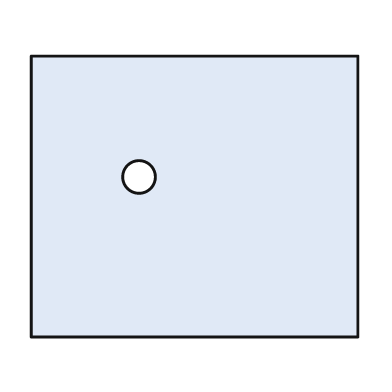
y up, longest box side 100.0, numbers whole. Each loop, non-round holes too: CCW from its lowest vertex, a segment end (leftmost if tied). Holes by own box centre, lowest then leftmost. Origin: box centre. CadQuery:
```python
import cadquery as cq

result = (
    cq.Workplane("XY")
    .moveTo(-50.0, -43.0)
    .lineTo(50.0, -43.0)
    .lineTo(50.0, 43.0)
    .lineTo(-50.0, 43.0)
    .close()
    .moveTo(-17.0, 6.0)
    .circle(5.0)
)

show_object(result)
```